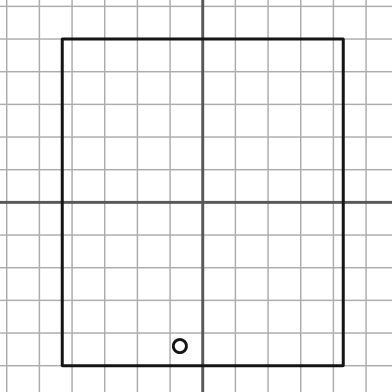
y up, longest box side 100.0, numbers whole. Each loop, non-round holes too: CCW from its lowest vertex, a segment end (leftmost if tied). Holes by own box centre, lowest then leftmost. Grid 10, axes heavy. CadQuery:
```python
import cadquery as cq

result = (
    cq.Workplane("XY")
    .moveTo(-43.0, -50.0)
    .lineTo(43.0, -50.0)
    .lineTo(43.0, 50.0)
    .lineTo(-43.0, 50.0)
    .close()
    .moveTo(-7.0, -44.0)
    .circle(2.0)
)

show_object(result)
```